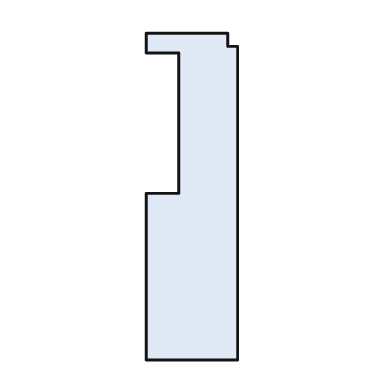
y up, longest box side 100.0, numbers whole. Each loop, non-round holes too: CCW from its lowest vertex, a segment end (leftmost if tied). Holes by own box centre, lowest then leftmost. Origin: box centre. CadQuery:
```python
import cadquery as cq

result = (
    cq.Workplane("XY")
    .moveTo(-14.0, -50.0)
    .lineTo(14.0, -50.0)
    .lineTo(14.0, 46.0)
    .lineTo(11.0, 46.0)
    .lineTo(11.0, 50.0)
    .lineTo(-14.0, 50.0)
    .lineTo(-14.0, 44.0)
    .lineTo(-4.0, 44.0)
    .lineTo(-4.0, 1.0)
    .lineTo(-14.0, 1.0)
    .close()
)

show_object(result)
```